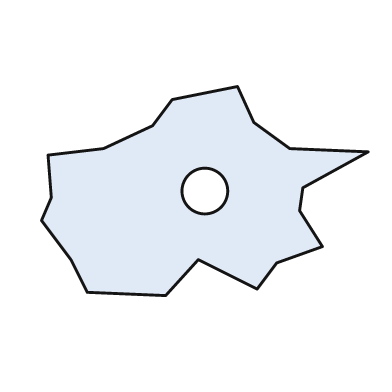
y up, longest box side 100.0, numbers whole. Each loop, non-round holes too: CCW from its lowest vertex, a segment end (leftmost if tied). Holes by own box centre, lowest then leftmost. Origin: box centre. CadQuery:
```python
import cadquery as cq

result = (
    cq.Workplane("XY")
    .moveTo(-12.0, -32.0)
    .lineTo(-2.0, -21.0)
    .lineTo(16.0, -30.0)
    .lineTo(22.0, -22.0)
    .lineTo(36.0, -17.0)
    .lineTo(29.0, -6.0)
    .lineTo(30.0, 1.0)
    .lineTo(50.0, 12.0)
    .lineTo(26.0, 13.0)
    .lineTo(15.0, 21.0)
    .lineTo(10.0, 32.0)
    .lineTo(-10.0, 28.0)
    .lineTo(-16.0, 20.0)
    .lineTo(-31.0, 13.0)
    .lineTo(-48.0, 11.0)
    .lineTo(-47.0, -2.0)
    .lineTo(-50.0, -9.0)
    .lineTo(-41.0, -21.0)
    .lineTo(-36.0, -31.0)
    .close()
    .moveTo(0.0, 0.0)
    .circle(7.0)
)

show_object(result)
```